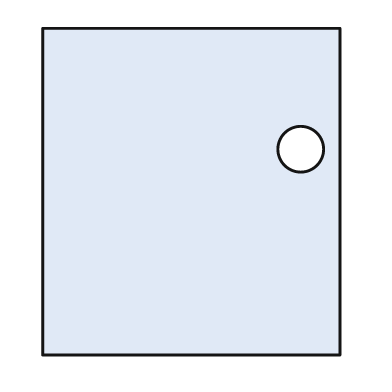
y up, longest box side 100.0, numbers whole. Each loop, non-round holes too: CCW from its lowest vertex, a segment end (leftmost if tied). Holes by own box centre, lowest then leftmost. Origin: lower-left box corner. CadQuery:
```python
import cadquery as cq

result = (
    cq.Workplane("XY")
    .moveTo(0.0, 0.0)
    .lineTo(91.0, 0.0)
    .lineTo(91.0, 100.0)
    .lineTo(0.0, 100.0)
    .close()
    .moveTo(79.0, 63.0)
    .circle(7.0)
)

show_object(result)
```